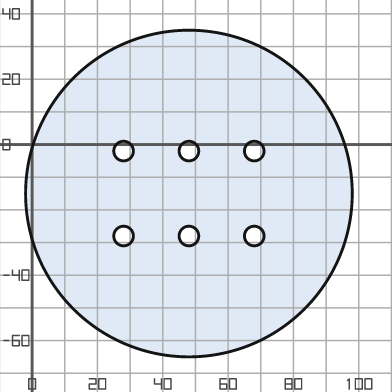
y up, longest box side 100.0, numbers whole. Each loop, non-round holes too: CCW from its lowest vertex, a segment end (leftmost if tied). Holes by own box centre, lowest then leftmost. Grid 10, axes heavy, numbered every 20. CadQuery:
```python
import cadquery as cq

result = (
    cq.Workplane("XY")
    .moveTo(48.0, -15.0)
    .circle(50.0)
    .moveTo(28.0, -28.0)
    .circle(3.0)
    .moveTo(48.0, -28.0)
    .circle(3.0)
    .moveTo(68.0, -28.0)
    .circle(3.0)
    .moveTo(28.0, -2.0)
    .circle(3.0)
    .moveTo(48.0, -2.0)
    .circle(3.0)
    .moveTo(68.0, -2.0)
    .circle(3.0)
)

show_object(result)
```